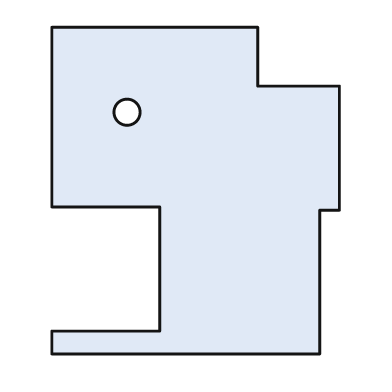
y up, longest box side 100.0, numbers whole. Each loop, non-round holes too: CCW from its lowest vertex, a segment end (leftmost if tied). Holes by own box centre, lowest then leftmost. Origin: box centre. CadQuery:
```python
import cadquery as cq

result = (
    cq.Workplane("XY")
    .moveTo(-44.0, -50.0)
    .lineTo(38.0, -50.0)
    .lineTo(38.0, -6.0)
    .lineTo(44.0, -6.0)
    .lineTo(44.0, 32.0)
    .lineTo(19.0, 32.0)
    .lineTo(19.0, 50.0)
    .lineTo(-44.0, 50.0)
    .lineTo(-44.0, -5.0)
    .lineTo(-11.0, -5.0)
    .lineTo(-11.0, -43.0)
    .lineTo(-44.0, -43.0)
    .close()
    .moveTo(-21.0, 24.0)
    .circle(4.0)
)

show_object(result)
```